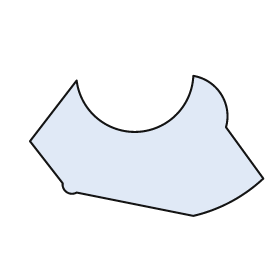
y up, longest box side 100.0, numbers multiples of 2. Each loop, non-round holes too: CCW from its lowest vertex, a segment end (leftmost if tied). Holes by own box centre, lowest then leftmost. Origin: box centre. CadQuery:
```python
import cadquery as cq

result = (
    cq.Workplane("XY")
    .moveTo(20.0, -30.0)
    .threePointArc((36.0, -24.0), (50.0, -14.0))
    .lineTo(34.0, 8.0)
    .threePointArc((32.0, 22.0), (20.0, 30.0))
    .threePointArc((-4.0, 6.0), (-30.0, 28.0))
    .lineTo(-50.0, 2.0)
    .lineTo(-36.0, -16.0)
    .threePointArc((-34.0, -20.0), (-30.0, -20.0))
    .close()
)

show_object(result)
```